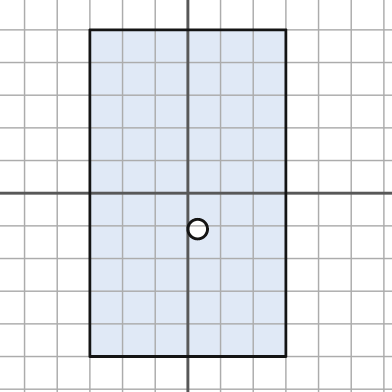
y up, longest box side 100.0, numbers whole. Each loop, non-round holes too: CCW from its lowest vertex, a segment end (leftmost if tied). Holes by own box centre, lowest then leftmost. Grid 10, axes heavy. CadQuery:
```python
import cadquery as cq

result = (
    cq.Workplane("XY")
    .moveTo(-30.0, -50.0)
    .lineTo(30.0, -50.0)
    .lineTo(30.0, 50.0)
    .lineTo(-30.0, 50.0)
    .close()
    .moveTo(3.0, -11.0)
    .circle(3.0)
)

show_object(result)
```